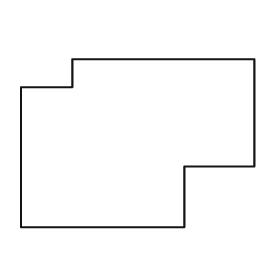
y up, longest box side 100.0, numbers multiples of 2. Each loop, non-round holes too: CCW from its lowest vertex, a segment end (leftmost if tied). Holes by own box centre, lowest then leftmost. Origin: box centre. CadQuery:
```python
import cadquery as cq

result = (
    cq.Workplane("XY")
    .moveTo(-50.0, -36.0)
    .lineTo(20.0, -36.0)
    .lineTo(20.0, -10.0)
    .lineTo(50.0, -10.0)
    .lineTo(50.0, 36.0)
    .lineTo(-28.0, 36.0)
    .lineTo(-28.0, 24.0)
    .lineTo(-50.0, 24.0)
    .close()
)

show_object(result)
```